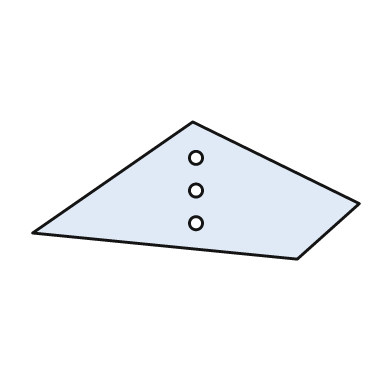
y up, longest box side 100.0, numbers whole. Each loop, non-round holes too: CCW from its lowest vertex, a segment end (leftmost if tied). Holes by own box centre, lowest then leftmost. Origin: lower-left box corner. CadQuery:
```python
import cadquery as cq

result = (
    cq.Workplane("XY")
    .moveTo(81.0, 0.0)
    .lineTo(100.0, 17.0)
    .lineTo(49.0, 42.0)
    .lineTo(0.0, 8.0)
    .close()
    .moveTo(50.0, 11.0)
    .circle(2.0)
    .moveTo(50.0, 21.0)
    .circle(2.0)
    .moveTo(50.0, 31.0)
    .circle(2.0)
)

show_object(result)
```